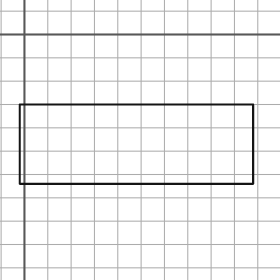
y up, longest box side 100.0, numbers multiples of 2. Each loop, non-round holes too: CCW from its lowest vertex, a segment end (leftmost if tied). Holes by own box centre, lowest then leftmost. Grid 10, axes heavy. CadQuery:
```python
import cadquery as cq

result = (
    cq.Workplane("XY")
    .moveTo(-2.0, -64.0)
    .lineTo(98.0, -64.0)
    .lineTo(98.0, -30.0)
    .lineTo(-2.0, -30.0)
    .close()
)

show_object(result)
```